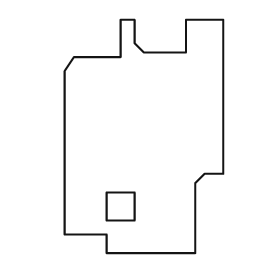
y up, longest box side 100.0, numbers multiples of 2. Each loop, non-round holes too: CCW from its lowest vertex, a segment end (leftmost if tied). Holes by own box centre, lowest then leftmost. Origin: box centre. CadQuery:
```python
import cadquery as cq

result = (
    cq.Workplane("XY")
    .moveTo(-16.0, -50.0)
    .lineTo(22.0, -50.0)
    .lineTo(22.0, -20.0)
    .lineTo(26.0, -16.0)
    .lineTo(34.0, -16.0)
    .lineTo(34.0, 50.0)
    .lineTo(18.0, 50.0)
    .lineTo(18.0, 36.0)
    .lineTo(0.0, 36.0)
    .lineTo(-4.0, 40.0)
    .lineTo(-4.0, 50.0)
    .lineTo(-10.0, 50.0)
    .lineTo(-10.0, 34.0)
    .lineTo(-30.0, 34.0)
    .lineTo(-34.0, 28.0)
    .lineTo(-34.0, -42.0)
    .lineTo(-16.0, -42.0)
    .close()
    .moveTo(-16.0, -36.0)
    .lineTo(-4.0, -36.0)
    .lineTo(-4.0, -24.0)
    .lineTo(-16.0, -24.0)
    .close()
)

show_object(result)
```